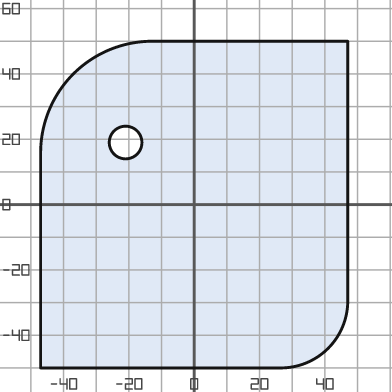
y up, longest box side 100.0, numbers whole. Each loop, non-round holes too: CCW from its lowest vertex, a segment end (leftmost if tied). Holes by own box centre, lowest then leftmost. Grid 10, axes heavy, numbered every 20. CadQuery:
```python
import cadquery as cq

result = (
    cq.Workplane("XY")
    .moveTo(-47.0, -50.0)
    .lineTo(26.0, -50.0)
    .threePointArc((41.0, -44.0), (47.0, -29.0))
    .lineTo(47.0, 50.0)
    .lineTo(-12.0, 50.0)
    .threePointArc((-37.0, 40.0), (-47.0, 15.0))
    .close()
    .moveTo(-21.0, 19.0)
    .circle(5.0)
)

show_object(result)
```